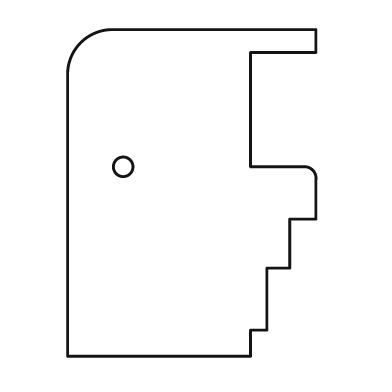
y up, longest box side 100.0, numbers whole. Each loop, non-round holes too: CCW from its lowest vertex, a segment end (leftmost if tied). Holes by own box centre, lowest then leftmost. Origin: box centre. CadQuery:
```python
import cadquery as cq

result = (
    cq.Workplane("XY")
    .moveTo(-38.0, -50.0)
    .lineTo(18.0, -50.0)
    .lineTo(18.0, -42.0)
    .lineTo(23.0, -42.0)
    .lineTo(23.0, -23.0)
    .lineTo(30.0, -23.0)
    .lineTo(30.0, -8.0)
    .lineTo(38.0, -8.0)
    .lineTo(38.0, 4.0)
    .threePointArc((37.0, 7.0), (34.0, 8.0))
    .lineTo(18.0, 8.0)
    .lineTo(18.0, 43.0)
    .lineTo(38.0, 43.0)
    .lineTo(38.0, 50.0)
    .lineTo(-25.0, 50.0)
    .threePointArc((-34.0, 46.0), (-38.0, 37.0))
    .close()
    .moveTo(-21.0, 8.0)
    .circle(3.0)
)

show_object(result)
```